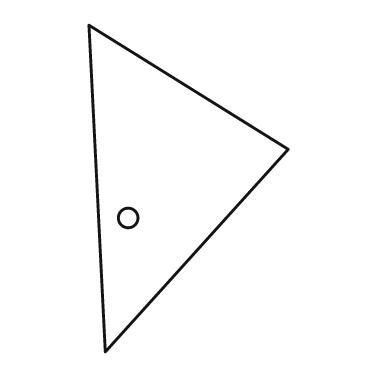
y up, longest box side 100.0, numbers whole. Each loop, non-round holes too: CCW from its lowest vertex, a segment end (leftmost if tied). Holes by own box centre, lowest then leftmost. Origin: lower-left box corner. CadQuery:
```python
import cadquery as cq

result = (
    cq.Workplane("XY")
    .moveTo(5.0, 0.0)
    .lineTo(61.0, 62.0)
    .lineTo(0.0, 100.0)
    .close()
    .moveTo(12.0, 41.0)
    .circle(3.0)
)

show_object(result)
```